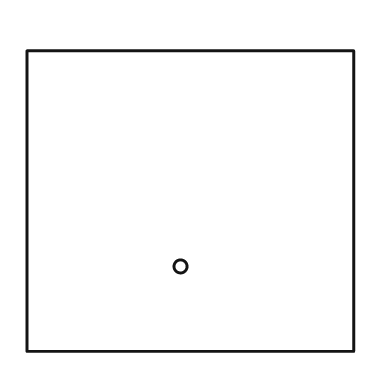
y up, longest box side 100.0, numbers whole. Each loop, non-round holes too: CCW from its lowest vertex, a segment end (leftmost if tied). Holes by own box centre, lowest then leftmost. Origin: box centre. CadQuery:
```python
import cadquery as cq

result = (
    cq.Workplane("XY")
    .moveTo(-50.0, -46.0)
    .lineTo(50.0, -46.0)
    .lineTo(50.0, 46.0)
    .lineTo(-50.0, 46.0)
    .close()
    .moveTo(-3.0, -20.0)
    .circle(2.0)
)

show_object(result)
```